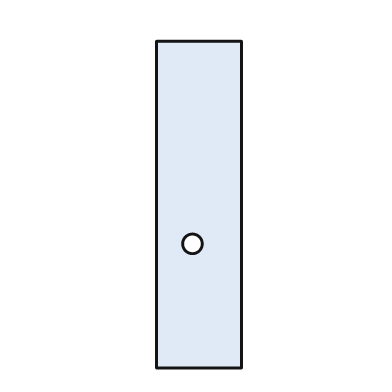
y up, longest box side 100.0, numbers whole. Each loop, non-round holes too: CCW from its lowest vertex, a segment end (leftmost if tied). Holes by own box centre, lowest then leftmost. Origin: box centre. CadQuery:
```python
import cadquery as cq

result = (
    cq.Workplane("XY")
    .moveTo(-13.0, -50.0)
    .lineTo(13.0, -50.0)
    .lineTo(13.0, 50.0)
    .lineTo(-13.0, 50.0)
    .close()
    .moveTo(-2.0, -12.0)
    .circle(3.0)
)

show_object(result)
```